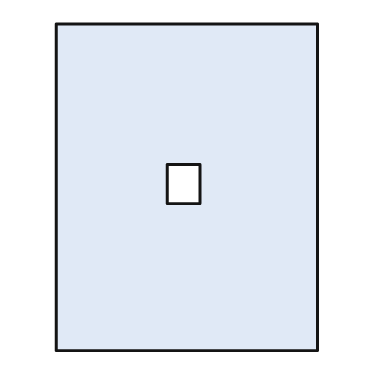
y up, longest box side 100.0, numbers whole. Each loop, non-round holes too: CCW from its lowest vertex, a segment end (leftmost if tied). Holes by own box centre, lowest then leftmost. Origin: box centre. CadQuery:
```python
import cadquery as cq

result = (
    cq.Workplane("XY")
    .moveTo(-40.0, -50.0)
    .lineTo(40.0, -50.0)
    .lineTo(40.0, 50.0)
    .lineTo(-40.0, 50.0)
    .close()
    .moveTo(-6.0, -5.0)
    .lineTo(4.0, -5.0)
    .lineTo(4.0, 7.0)
    .lineTo(-6.0, 7.0)
    .close()
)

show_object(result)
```